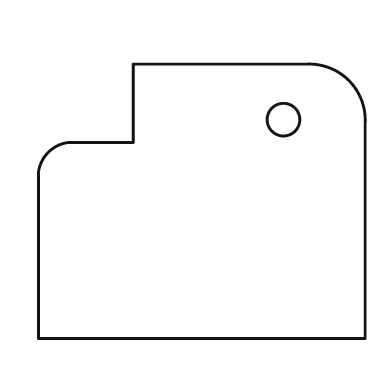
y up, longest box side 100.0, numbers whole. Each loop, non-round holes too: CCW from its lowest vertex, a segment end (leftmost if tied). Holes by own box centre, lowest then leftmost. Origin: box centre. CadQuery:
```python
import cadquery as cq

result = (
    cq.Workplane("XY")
    .moveTo(-50.0, -42.0)
    .lineTo(50.0, -42.0)
    .lineTo(50.0, 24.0)
    .threePointArc((45.0, 37.0), (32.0, 42.0))
    .lineTo(-21.0, 42.0)
    .lineTo(-21.0, 18.0)
    .lineTo(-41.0, 18.0)
    .threePointArc((-47.0, 15.0), (-50.0, 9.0))
    .close()
    .moveTo(25.0, 25.0)
    .circle(5.0)
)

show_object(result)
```